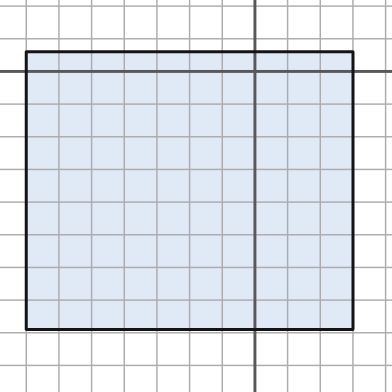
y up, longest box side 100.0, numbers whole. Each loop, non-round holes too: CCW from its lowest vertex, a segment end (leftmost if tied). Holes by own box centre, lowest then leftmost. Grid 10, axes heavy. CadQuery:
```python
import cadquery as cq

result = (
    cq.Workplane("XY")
    .moveTo(-70.0, -79.0)
    .lineTo(30.0, -79.0)
    .lineTo(30.0, 6.0)
    .lineTo(-70.0, 6.0)
    .close()
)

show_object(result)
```